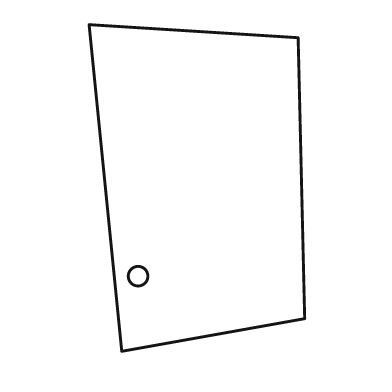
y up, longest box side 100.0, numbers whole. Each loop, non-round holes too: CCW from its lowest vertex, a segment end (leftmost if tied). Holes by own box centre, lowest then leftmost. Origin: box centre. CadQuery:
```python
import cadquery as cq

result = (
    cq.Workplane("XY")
    .moveTo(-23.0, -50.0)
    .lineTo(33.0, -40.0)
    .lineTo(31.0, 46.0)
    .lineTo(-33.0, 50.0)
    .close()
    .moveTo(-18.0, -27.0)
    .circle(3.0)
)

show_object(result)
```